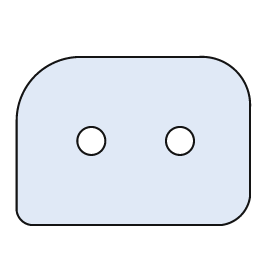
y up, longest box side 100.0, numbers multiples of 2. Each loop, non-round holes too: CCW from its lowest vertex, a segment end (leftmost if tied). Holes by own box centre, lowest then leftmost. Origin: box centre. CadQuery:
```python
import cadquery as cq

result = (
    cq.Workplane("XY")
    .moveTo(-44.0, -36.0)
    .lineTo(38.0, -36.0)
    .threePointArc((46.0, -32.0), (50.0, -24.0))
    .lineTo(50.0, 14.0)
    .threePointArc((44.0, 30.0), (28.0, 36.0))
    .lineTo(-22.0, 36.0)
    .threePointArc((-42.0, 28.0), (-50.0, 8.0))
    .lineTo(-50.0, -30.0)
    .threePointArc((-48.0, -34.0), (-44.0, -36.0))
    .close()
    .moveTo(-18.0, 0.0)
    .circle(6.0)
    .moveTo(20.0, 0.0)
    .circle(6.0)
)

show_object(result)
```